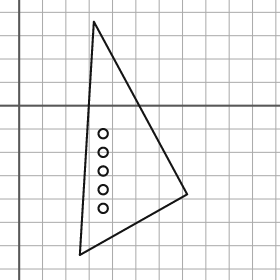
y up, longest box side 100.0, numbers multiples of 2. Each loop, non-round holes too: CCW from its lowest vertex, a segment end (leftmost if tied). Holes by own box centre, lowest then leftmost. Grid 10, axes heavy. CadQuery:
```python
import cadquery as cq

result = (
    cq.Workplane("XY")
    .moveTo(26.0, -64.0)
    .lineTo(72.0, -38.0)
    .lineTo(32.0, 36.0)
    .close()
    .moveTo(36.0, -44.0)
    .circle(2.0)
    .moveTo(36.0, -36.0)
    .circle(2.0)
    .moveTo(36.0, -28.0)
    .circle(2.0)
    .moveTo(36.0, -20.0)
    .circle(2.0)
    .moveTo(36.0, -12.0)
    .circle(2.0)
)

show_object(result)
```